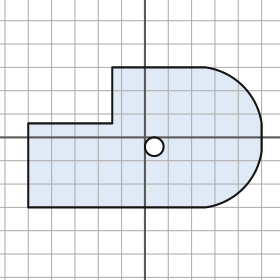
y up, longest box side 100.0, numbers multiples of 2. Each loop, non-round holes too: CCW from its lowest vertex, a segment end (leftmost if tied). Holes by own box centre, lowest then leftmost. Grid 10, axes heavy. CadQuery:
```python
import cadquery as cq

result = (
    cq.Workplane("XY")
    .moveTo(-50.0, -30.0)
    .lineTo(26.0, -30.0)
    .threePointArc((42.0, -22.0), (50.0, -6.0))
    .lineTo(50.0, 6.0)
    .threePointArc((42.0, 22.0), (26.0, 30.0))
    .lineTo(-14.0, 30.0)
    .lineTo(-14.0, 6.0)
    .lineTo(-50.0, 6.0)
    .close()
    .moveTo(4.0, -4.0)
    .circle(4.0)
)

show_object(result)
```